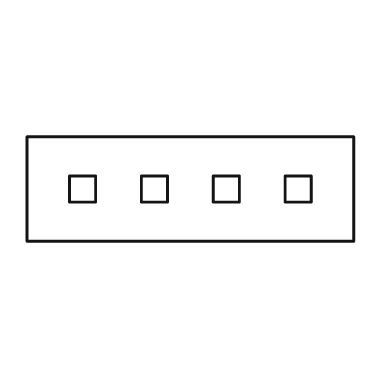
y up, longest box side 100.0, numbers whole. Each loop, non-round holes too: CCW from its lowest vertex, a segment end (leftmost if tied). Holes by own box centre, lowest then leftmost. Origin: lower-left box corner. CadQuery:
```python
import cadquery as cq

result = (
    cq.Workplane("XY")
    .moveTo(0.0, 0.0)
    .lineTo(100.0, 0.0)
    .lineTo(100.0, 32.0)
    .lineTo(0.0, 32.0)
    .close()
    .moveTo(13.0, 12.0)
    .lineTo(21.0, 12.0)
    .lineTo(21.0, 20.0)
    .lineTo(13.0, 20.0)
    .close()
    .moveTo(35.0, 12.0)
    .lineTo(43.0, 12.0)
    .lineTo(43.0, 20.0)
    .lineTo(35.0, 20.0)
    .close()
    .moveTo(57.0, 12.0)
    .lineTo(65.0, 12.0)
    .lineTo(65.0, 20.0)
    .lineTo(57.0, 20.0)
    .close()
    .moveTo(79.0, 12.0)
    .lineTo(87.0, 12.0)
    .lineTo(87.0, 20.0)
    .lineTo(79.0, 20.0)
    .close()
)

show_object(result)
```